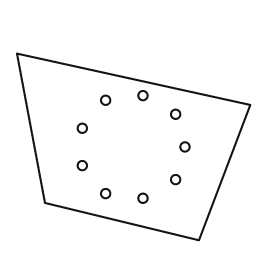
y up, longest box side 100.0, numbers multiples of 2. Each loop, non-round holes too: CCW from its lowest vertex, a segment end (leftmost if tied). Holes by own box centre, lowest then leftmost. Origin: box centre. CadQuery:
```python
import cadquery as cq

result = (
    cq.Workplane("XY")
    .moveTo(28.0, -40.0)
    .lineTo(50.0, 18.0)
    .lineTo(-50.0, 40.0)
    .lineTo(-38.0, -24.0)
    .close()
    .moveTo(4.0, -22.0)
    .circle(2.0)
    .moveTo(-12.0, -20.0)
    .circle(2.0)
    .moveTo(18.0, -14.0)
    .circle(2.0)
    .moveTo(-22.0, -8.0)
    .circle(2.0)
    .moveTo(22.0, 0.0)
    .circle(2.0)
    .moveTo(-22.0, 8.0)
    .circle(2.0)
    .moveTo(18.0, 14.0)
    .circle(2.0)
    .moveTo(-12.0, 20.0)
    .circle(2.0)
    .moveTo(4.0, 22.0)
    .circle(2.0)
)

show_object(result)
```